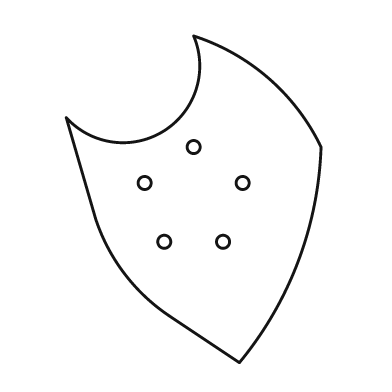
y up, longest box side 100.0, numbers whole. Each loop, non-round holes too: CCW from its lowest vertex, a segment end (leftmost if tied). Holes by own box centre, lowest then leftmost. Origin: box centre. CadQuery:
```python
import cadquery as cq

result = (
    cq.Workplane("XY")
    .moveTo(14.0, -50.0)
    .threePointArc((32.0, -19.0), (39.0, 16.0))
    .threePointArc((23.0, 37.0), (0.0, 50.0))
    .threePointArc((-9.0, 21.0), (-39.0, 25.0))
    .lineTo(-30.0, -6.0)
    .threePointArc((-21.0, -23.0), (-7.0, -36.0))
    .close()
    .moveTo(-9.0, -13.0)
    .circle(2.0)
    .moveTo(9.0, -13.0)
    .circle(2.0)
    .moveTo(-15.0, 5.0)
    .circle(2.0)
    .moveTo(15.0, 5.0)
    .circle(2.0)
    .moveTo(0.0, 16.0)
    .circle(2.0)
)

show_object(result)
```